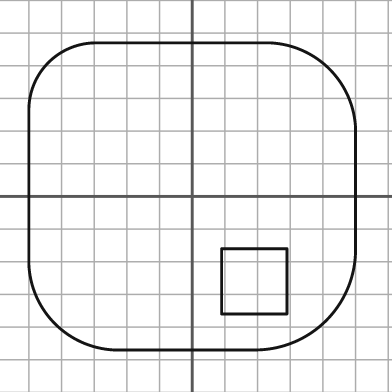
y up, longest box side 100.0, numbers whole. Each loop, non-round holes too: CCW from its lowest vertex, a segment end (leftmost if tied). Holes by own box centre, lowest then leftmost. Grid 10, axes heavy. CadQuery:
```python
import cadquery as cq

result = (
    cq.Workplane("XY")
    .moveTo(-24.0, -47.0)
    .lineTo(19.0, -47.0)
    .threePointArc((41.0, -38.0), (50.0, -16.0))
    .lineTo(50.0, 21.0)
    .threePointArc((42.0, 39.0), (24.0, 47.0))
    .lineTo(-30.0, 47.0)
    .threePointArc((-44.0, 41.0), (-50.0, 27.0))
    .lineTo(-50.0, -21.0)
    .threePointArc((-42.0, -39.0), (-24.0, -47.0))
    .close()
    .moveTo(9.0, -36.0)
    .lineTo(29.0, -36.0)
    .lineTo(29.0, -16.0)
    .lineTo(9.0, -16.0)
    .close()
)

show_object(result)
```